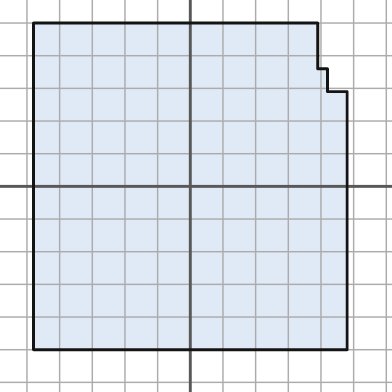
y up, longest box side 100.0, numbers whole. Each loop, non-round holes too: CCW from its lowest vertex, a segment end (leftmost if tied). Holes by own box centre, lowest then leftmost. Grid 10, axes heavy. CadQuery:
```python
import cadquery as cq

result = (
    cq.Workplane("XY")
    .moveTo(-48.0, -50.0)
    .lineTo(48.0, -50.0)
    .lineTo(48.0, 29.0)
    .lineTo(42.0, 29.0)
    .lineTo(42.0, 36.0)
    .lineTo(39.0, 36.0)
    .lineTo(39.0, 50.0)
    .lineTo(-48.0, 50.0)
    .close()
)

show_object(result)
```